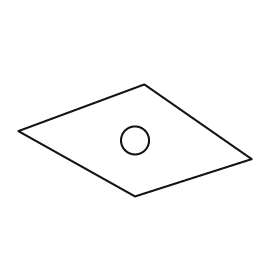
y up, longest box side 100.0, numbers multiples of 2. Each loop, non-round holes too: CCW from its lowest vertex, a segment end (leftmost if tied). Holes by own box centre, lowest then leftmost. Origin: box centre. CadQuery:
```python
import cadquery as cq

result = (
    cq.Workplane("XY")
    .moveTo(0.0, -24.0)
    .lineTo(50.0, -8.0)
    .lineTo(4.0, 24.0)
    .lineTo(-50.0, 4.0)
    .close()
    .moveTo(0.0, 0.0)
    .circle(6.0)
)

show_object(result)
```